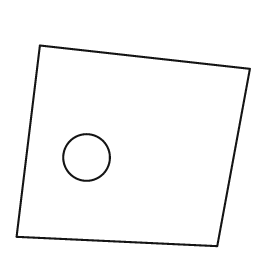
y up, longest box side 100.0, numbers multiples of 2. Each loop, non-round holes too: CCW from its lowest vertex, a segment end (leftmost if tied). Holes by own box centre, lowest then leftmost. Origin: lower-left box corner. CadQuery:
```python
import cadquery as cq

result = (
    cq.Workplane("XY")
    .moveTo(86.0, 0.0)
    .lineTo(100.0, 76.0)
    .lineTo(10.0, 86.0)
    .lineTo(0.0, 4.0)
    .close()
    .moveTo(30.0, 38.0)
    .circle(10.0)
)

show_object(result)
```